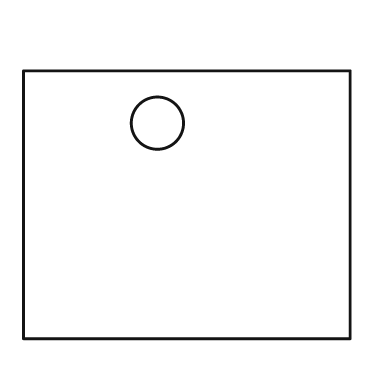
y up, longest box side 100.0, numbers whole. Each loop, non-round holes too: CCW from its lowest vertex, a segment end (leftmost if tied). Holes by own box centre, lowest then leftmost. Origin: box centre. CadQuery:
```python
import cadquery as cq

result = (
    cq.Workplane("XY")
    .moveTo(-50.0, -41.0)
    .lineTo(50.0, -41.0)
    .lineTo(50.0, 41.0)
    .lineTo(-50.0, 41.0)
    .close()
    .moveTo(-9.0, 25.0)
    .circle(8.0)
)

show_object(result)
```